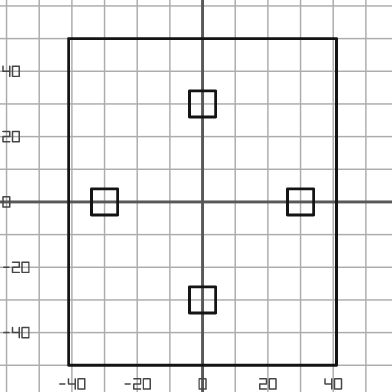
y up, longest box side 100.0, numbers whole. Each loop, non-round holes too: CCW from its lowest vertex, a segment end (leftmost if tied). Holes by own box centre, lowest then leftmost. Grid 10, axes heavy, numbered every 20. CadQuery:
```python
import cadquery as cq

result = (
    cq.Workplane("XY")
    .moveTo(-41.0, -50.0)
    .lineTo(41.0, -50.0)
    .lineTo(41.0, 50.0)
    .lineTo(-41.0, 50.0)
    .close()
    .moveTo(-4.0, -34.0)
    .lineTo(4.0, -34.0)
    .lineTo(4.0, -26.0)
    .lineTo(-4.0, -26.0)
    .close()
    .moveTo(-34.0, -4.0)
    .lineTo(-26.0, -4.0)
    .lineTo(-26.0, 4.0)
    .lineTo(-34.0, 4.0)
    .close()
    .moveTo(26.0, -4.0)
    .lineTo(34.0, -4.0)
    .lineTo(34.0, 4.0)
    .lineTo(26.0, 4.0)
    .close()
    .moveTo(-4.0, 26.0)
    .lineTo(4.0, 26.0)
    .lineTo(4.0, 34.0)
    .lineTo(-4.0, 34.0)
    .close()
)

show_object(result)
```